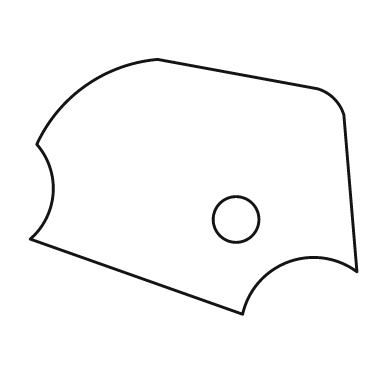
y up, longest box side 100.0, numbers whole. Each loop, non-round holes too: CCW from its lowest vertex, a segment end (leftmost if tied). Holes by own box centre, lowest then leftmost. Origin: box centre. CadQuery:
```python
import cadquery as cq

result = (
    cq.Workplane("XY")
    .moveTo(15.0, -39.0)
    .threePointArc((29.0, -23.0), (50.0, -26.0))
    .lineTo(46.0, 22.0)
    .threePointArc((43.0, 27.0), (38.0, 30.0))
    .lineTo(-11.0, 39.0)
    .threePointArc((-33.0, 31.0), (-48.0, 13.0))
    .threePointArc((-43.0, -2.0), (-50.0, -16.0))
    .close()
    .moveTo(13.0, -10.0)
    .circle(7.0)
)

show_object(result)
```